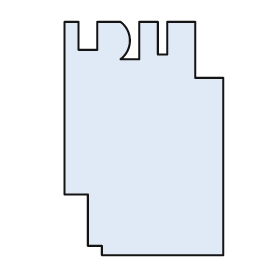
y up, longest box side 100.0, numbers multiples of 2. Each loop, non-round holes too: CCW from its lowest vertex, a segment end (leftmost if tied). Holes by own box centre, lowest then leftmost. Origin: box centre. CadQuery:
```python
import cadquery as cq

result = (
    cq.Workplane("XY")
    .moveTo(-18.0, -50.0)
    .lineTo(34.0, -50.0)
    .lineTo(34.0, 26.0)
    .lineTo(22.0, 26.0)
    .lineTo(22.0, 50.0)
    .lineTo(10.0, 50.0)
    .lineTo(10.0, 36.0)
    .lineTo(6.0, 36.0)
    .lineTo(6.0, 50.0)
    .lineTo(-2.0, 50.0)
    .lineTo(-2.0, 34.0)
    .lineTo(-10.0, 34.0)
    .threePointArc((-6.0, 42.0), (-10.0, 50.0))
    .lineTo(-20.0, 50.0)
    .lineTo(-20.0, 38.0)
    .lineTo(-28.0, 38.0)
    .lineTo(-28.0, 50.0)
    .lineTo(-34.0, 50.0)
    .lineTo(-34.0, -24.0)
    .lineTo(-24.0, -24.0)
    .lineTo(-24.0, -46.0)
    .lineTo(-18.0, -46.0)
    .close()
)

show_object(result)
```